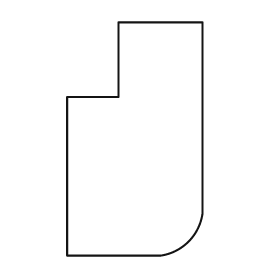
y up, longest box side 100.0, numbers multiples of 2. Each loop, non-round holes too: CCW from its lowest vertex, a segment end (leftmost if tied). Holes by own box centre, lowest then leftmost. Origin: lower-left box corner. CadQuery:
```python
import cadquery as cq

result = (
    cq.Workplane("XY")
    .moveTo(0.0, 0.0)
    .lineTo(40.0, 0.0)
    .threePointArc((52.0, 6.0), (58.0, 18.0))
    .lineTo(58.0, 100.0)
    .lineTo(22.0, 100.0)
    .lineTo(22.0, 68.0)
    .lineTo(0.0, 68.0)
    .close()
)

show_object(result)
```